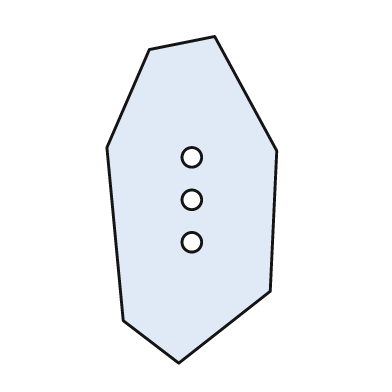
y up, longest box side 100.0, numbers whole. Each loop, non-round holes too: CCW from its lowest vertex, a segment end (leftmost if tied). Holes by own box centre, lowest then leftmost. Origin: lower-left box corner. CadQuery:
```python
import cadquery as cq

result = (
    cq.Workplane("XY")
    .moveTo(22.0, 0.0)
    .lineTo(50.0, 22.0)
    .lineTo(52.0, 65.0)
    .lineTo(33.0, 100.0)
    .lineTo(13.0, 96.0)
    .lineTo(0.0, 66.0)
    .lineTo(5.0, 13.0)
    .close()
    .moveTo(26.0, 37.0)
    .circle(3.0)
    .moveTo(26.0, 50.0)
    .circle(3.0)
    .moveTo(26.0, 63.0)
    .circle(3.0)
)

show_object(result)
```